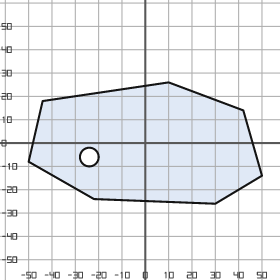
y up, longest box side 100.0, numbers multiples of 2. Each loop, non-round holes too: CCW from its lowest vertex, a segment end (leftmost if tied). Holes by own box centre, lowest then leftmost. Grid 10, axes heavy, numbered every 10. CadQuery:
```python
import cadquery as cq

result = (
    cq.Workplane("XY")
    .moveTo(30.0, -26.0)
    .lineTo(50.0, -14.0)
    .lineTo(42.0, 14.0)
    .lineTo(10.0, 26.0)
    .lineTo(-44.0, 18.0)
    .lineTo(-50.0, -8.0)
    .lineTo(-22.0, -24.0)
    .close()
    .moveTo(-24.0, -6.0)
    .circle(4.0)
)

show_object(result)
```